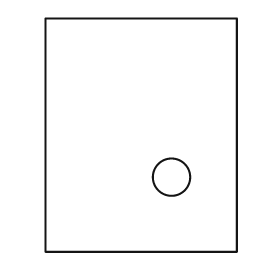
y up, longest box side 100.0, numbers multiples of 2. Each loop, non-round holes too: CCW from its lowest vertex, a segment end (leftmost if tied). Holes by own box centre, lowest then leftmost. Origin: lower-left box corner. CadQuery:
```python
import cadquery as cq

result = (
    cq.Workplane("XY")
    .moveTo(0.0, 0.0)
    .lineTo(82.0, 0.0)
    .lineTo(82.0, 100.0)
    .lineTo(0.0, 100.0)
    .close()
    .moveTo(54.0, 32.0)
    .circle(8.0)
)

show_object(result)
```